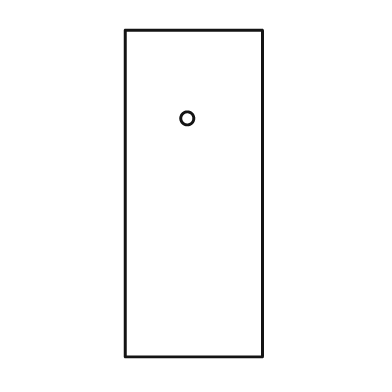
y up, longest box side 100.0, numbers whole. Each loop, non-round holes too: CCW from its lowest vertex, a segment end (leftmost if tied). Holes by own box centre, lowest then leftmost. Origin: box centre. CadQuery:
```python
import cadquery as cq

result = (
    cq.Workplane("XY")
    .moveTo(-21.0, -50.0)
    .lineTo(21.0, -50.0)
    .lineTo(21.0, 50.0)
    .lineTo(-21.0, 50.0)
    .close()
    .moveTo(-2.0, 23.0)
    .circle(2.0)
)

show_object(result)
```